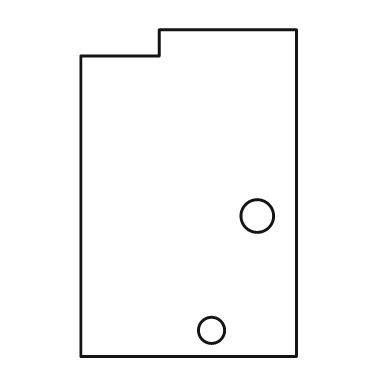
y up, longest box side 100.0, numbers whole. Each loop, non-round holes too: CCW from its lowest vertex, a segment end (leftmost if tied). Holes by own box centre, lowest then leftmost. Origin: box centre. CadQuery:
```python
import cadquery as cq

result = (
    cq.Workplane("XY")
    .moveTo(-33.0, -50.0)
    .lineTo(33.0, -50.0)
    .lineTo(33.0, 50.0)
    .lineTo(-9.0, 50.0)
    .lineTo(-9.0, 42.0)
    .lineTo(-33.0, 42.0)
    .close()
    .moveTo(7.0, -42.0)
    .circle(4.0)
    .moveTo(21.0, -7.0)
    .circle(5.0)
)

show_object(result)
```